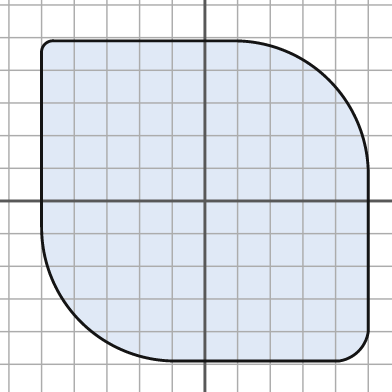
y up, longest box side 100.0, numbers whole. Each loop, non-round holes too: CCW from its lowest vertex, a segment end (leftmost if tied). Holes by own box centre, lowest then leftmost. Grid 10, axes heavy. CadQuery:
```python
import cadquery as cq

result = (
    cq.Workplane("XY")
    .moveTo(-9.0, -49.0)
    .lineTo(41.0, -49.0)
    .threePointArc((47.0, -46.0), (50.0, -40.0))
    .lineTo(50.0, 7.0)
    .threePointArc((38.0, 37.0), (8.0, 49.0))
    .lineTo(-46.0, 49.0)
    .threePointArc((-49.0, 48.0), (-50.0, 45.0))
    .lineTo(-50.0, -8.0)
    .threePointArc((-38.0, -37.0), (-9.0, -49.0))
    .close()
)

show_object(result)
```